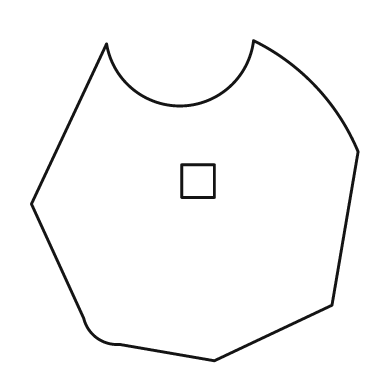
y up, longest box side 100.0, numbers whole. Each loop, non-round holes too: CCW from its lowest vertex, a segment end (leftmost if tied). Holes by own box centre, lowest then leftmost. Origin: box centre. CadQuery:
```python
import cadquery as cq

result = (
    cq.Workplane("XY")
    .moveTo(6.0, -49.0)
    .lineTo(42.0, -32.0)
    .lineTo(50.0, 15.0)
    .threePointArc((37.0, 35.0), (18.0, 49.0))
    .threePointArc((-4.0, 29.0), (-27.0, 48.0))
    .lineTo(-50.0, -1.0)
    .lineTo(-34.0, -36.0)
    .threePointArc((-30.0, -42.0), (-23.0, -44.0))
    .close()
    .moveTo(-4.0, 1.0)
    .lineTo(6.0, 1.0)
    .lineTo(6.0, 11.0)
    .lineTo(-4.0, 11.0)
    .close()
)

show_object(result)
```